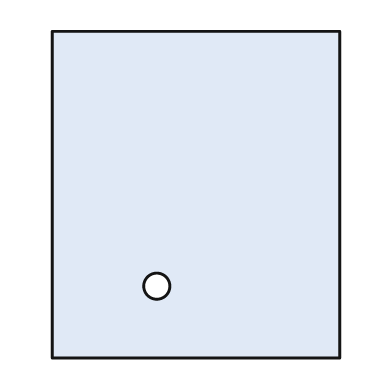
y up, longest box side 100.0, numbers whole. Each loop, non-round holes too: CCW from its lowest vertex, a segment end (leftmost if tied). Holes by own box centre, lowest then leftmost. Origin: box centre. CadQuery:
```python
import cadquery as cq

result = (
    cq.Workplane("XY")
    .moveTo(-44.0, -50.0)
    .lineTo(44.0, -50.0)
    .lineTo(44.0, 50.0)
    .lineTo(-44.0, 50.0)
    .close()
    .moveTo(-12.0, -28.0)
    .circle(4.0)
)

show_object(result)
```